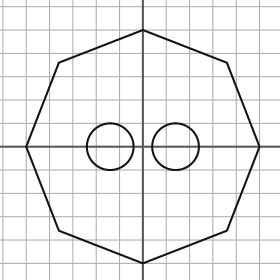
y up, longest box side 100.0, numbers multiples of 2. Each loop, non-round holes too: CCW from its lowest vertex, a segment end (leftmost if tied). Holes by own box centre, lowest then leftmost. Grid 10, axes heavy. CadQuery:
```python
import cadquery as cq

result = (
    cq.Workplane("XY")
    .moveTo(0.0, -50.0)
    .lineTo(36.0, -36.0)
    .lineTo(50.0, 0.0)
    .lineTo(36.0, 36.0)
    .lineTo(0.0, 50.0)
    .lineTo(-36.0, 36.0)
    .lineTo(-50.0, 0.0)
    .lineTo(-36.0, -36.0)
    .close()
    .moveTo(-14.0, 0.0)
    .circle(10.0)
    .moveTo(14.0, 0.0)
    .circle(10.0)
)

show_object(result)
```